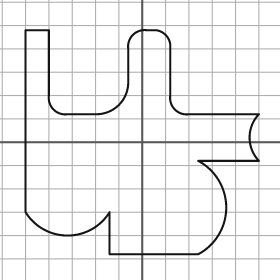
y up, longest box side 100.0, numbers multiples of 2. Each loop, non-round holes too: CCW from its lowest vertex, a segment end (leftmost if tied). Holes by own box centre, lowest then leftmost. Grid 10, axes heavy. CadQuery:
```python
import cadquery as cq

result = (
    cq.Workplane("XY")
    .moveTo(-14.0, -48.0)
    .lineTo(24.0, -48.0)
    .threePointArc((36.0, -28.0), (24.0, -8.0))
    .lineTo(50.0, -8.0)
    .threePointArc((46.0, 2.0), (50.0, 12.0))
    .lineTo(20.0, 12.0)
    .threePointArc((14.0, 14.0), (12.0, 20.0))
    .lineTo(12.0, 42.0)
    .threePointArc((10.0, 46.0), (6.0, 48.0))
    .lineTo(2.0, 48.0)
    .threePointArc((-4.0, 46.0), (-6.0, 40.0))
    .lineTo(-6.0, 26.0)
    .threePointArc((-10.0, 16.0), (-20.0, 12.0))
    .lineTo(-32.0, 12.0)
    .threePointArc((-38.0, 14.0), (-40.0, 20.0))
    .lineTo(-40.0, 48.0)
    .lineTo(-50.0, 48.0)
    .lineTo(-50.0, -30.0)
    .threePointArc((-32.0, -40.0), (-14.0, -30.0))
    .close()
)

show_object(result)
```